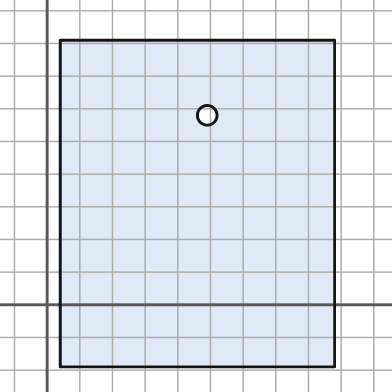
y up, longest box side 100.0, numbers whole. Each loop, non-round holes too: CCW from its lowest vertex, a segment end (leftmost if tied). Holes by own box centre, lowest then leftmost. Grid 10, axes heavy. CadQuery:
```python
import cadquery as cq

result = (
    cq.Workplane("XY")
    .moveTo(4.0, -19.0)
    .lineTo(88.0, -19.0)
    .lineTo(88.0, 81.0)
    .lineTo(4.0, 81.0)
    .close()
    .moveTo(49.0, 58.0)
    .circle(3.0)
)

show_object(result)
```